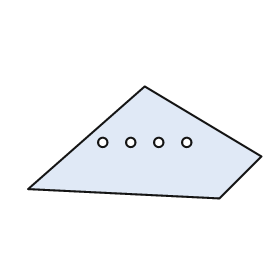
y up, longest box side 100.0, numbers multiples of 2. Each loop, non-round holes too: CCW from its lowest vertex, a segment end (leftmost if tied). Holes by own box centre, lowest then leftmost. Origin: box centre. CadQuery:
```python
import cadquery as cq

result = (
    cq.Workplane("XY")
    .moveTo(32.0, -24.0)
    .lineTo(50.0, -6.0)
    .lineTo(0.0, 24.0)
    .lineTo(-50.0, -20.0)
    .close()
    .moveTo(-18.0, 0.0)
    .circle(2.0)
    .moveTo(-6.0, 0.0)
    .circle(2.0)
    .moveTo(6.0, 0.0)
    .circle(2.0)
    .moveTo(18.0, 0.0)
    .circle(2.0)
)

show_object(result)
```